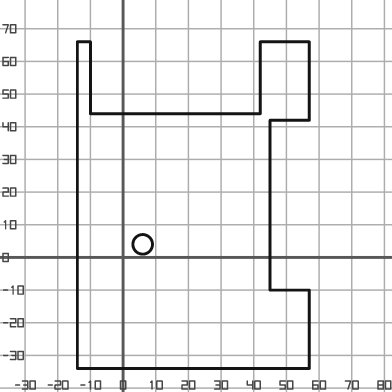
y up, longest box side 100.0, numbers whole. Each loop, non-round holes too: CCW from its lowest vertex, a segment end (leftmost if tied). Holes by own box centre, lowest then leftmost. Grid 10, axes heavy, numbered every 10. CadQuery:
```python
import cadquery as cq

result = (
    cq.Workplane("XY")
    .moveTo(-14.0, -34.0)
    .lineTo(57.0, -34.0)
    .lineTo(57.0, -10.0)
    .lineTo(45.0, -10.0)
    .lineTo(45.0, 42.0)
    .lineTo(57.0, 42.0)
    .lineTo(57.0, 66.0)
    .lineTo(42.0, 66.0)
    .lineTo(42.0, 44.0)
    .lineTo(-10.0, 44.0)
    .lineTo(-10.0, 66.0)
    .lineTo(-14.0, 66.0)
    .close()
    .moveTo(6.0, 4.0)
    .circle(3.0)
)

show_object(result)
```